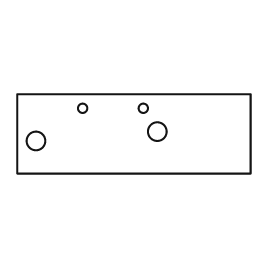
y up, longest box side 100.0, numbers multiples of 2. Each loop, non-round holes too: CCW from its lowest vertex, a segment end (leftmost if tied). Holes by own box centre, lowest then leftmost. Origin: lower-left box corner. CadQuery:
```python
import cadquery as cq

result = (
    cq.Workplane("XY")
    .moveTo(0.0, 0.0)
    .lineTo(100.0, 0.0)
    .lineTo(100.0, 34.0)
    .lineTo(0.0, 34.0)
    .close()
    .moveTo(8.0, 14.0)
    .circle(4.0)
    .moveTo(60.0, 18.0)
    .circle(4.0)
    .moveTo(28.0, 28.0)
    .circle(2.0)
    .moveTo(54.0, 28.0)
    .circle(2.0)
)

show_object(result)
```